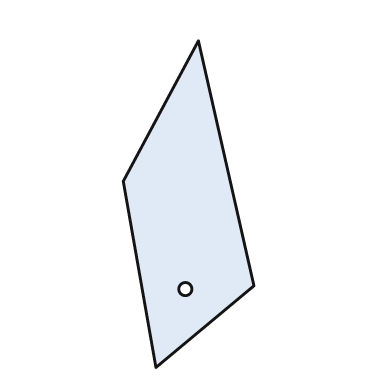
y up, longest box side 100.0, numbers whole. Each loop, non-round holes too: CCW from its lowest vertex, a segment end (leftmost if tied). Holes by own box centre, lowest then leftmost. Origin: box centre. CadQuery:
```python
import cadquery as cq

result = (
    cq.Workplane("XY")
    .moveTo(-10.0, -50.0)
    .lineTo(20.0, -25.0)
    .lineTo(3.0, 50.0)
    .lineTo(-20.0, 7.0)
    .close()
    .moveTo(-1.0, -26.0)
    .circle(2.0)
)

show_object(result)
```